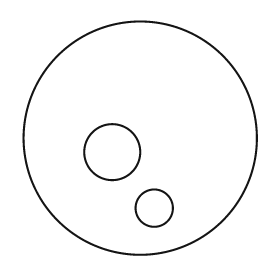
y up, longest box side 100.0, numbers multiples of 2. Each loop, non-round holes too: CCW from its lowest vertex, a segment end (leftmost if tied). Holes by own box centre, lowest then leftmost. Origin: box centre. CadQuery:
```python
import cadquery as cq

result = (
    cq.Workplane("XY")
    .moveTo(0.0, 0.0)
    .circle(50.0)
    .moveTo(6.0, -30.0)
    .circle(8.0)
    .moveTo(-12.0, -6.0)
    .circle(12.0)
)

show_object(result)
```